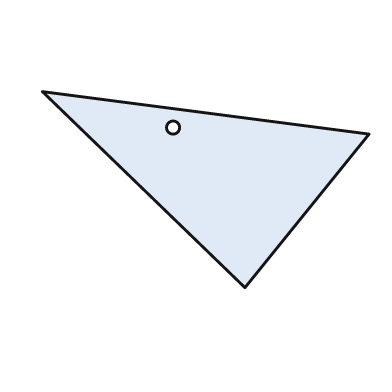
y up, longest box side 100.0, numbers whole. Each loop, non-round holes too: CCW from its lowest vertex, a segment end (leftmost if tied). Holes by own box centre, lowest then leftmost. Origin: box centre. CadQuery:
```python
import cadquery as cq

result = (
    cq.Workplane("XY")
    .moveTo(12.0, -30.0)
    .lineTo(50.0, 17.0)
    .lineTo(-50.0, 30.0)
    .close()
    .moveTo(-10.0, 19.0)
    .circle(2.0)
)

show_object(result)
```